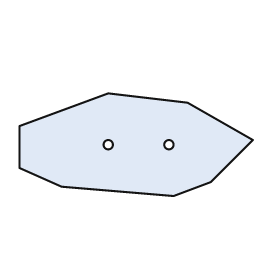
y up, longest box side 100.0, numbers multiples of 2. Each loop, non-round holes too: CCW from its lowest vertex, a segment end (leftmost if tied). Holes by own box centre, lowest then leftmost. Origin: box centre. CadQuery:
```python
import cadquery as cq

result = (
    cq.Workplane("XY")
    .moveTo(16.0, -22.0)
    .lineTo(32.0, -16.0)
    .lineTo(50.0, 2.0)
    .lineTo(22.0, 18.0)
    .lineTo(-12.0, 22.0)
    .lineTo(-50.0, 8.0)
    .lineTo(-50.0, -10.0)
    .lineTo(-32.0, -18.0)
    .close()
    .moveTo(-12.0, 0.0)
    .circle(2.0)
    .moveTo(14.0, 0.0)
    .circle(2.0)
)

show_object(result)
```